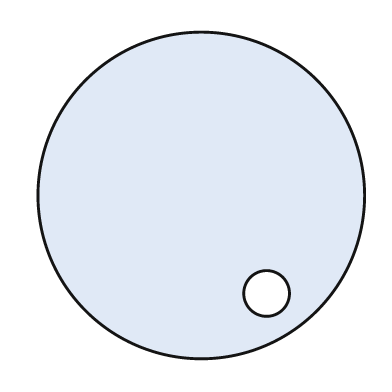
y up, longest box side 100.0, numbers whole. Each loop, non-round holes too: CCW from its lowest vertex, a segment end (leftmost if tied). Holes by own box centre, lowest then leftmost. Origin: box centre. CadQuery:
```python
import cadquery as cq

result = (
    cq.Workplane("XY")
    .moveTo(0.0, 0.0)
    .circle(50.0)
    .moveTo(20.0, -30.0)
    .circle(7.0)
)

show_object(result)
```